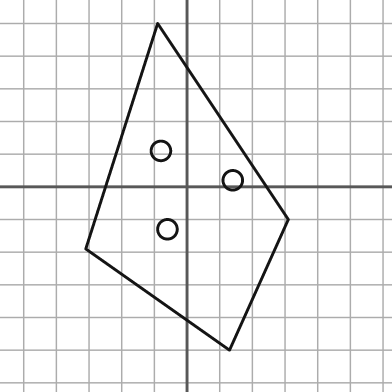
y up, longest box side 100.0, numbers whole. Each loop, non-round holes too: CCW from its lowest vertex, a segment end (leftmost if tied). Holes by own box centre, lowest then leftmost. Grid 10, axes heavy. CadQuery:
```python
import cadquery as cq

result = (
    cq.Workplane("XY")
    .moveTo(13.0, -50.0)
    .lineTo(31.0, -10.0)
    .lineTo(-9.0, 50.0)
    .lineTo(-31.0, -19.0)
    .close()
    .moveTo(-6.0, -13.0)
    .circle(3.0)
    .moveTo(14.0, 2.0)
    .circle(3.0)
    .moveTo(-8.0, 11.0)
    .circle(3.0)
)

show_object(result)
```